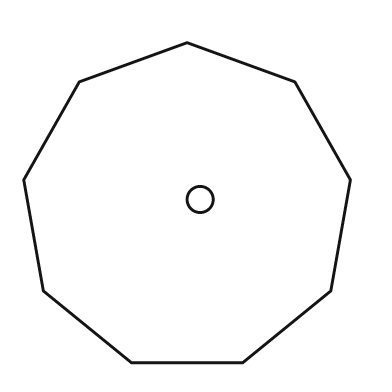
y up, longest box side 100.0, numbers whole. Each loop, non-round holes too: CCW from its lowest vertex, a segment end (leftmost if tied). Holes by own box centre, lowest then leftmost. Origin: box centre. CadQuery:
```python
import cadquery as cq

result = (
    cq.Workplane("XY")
    .moveTo(-17.0, -49.0)
    .lineTo(17.0, -49.0)
    .lineTo(44.0, -27.0)
    .lineTo(50.0, 7.0)
    .lineTo(33.0, 37.0)
    .lineTo(0.0, 49.0)
    .lineTo(-33.0, 37.0)
    .lineTo(-50.0, 7.0)
    .lineTo(-44.0, -27.0)
    .close()
    .moveTo(4.0, 1.0)
    .circle(4.0)
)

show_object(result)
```